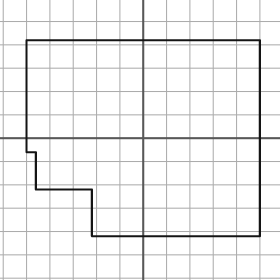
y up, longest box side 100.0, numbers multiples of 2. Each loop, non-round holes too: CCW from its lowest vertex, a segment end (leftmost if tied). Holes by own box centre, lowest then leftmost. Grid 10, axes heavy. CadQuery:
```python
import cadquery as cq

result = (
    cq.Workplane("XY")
    .moveTo(-22.0, -42.0)
    .lineTo(50.0, -42.0)
    .lineTo(50.0, 42.0)
    .lineTo(-50.0, 42.0)
    .lineTo(-50.0, -6.0)
    .lineTo(-46.0, -6.0)
    .lineTo(-46.0, -22.0)
    .lineTo(-22.0, -22.0)
    .close()
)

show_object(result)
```